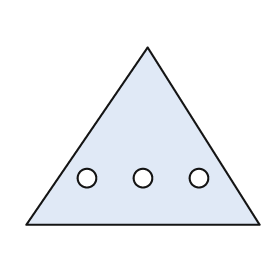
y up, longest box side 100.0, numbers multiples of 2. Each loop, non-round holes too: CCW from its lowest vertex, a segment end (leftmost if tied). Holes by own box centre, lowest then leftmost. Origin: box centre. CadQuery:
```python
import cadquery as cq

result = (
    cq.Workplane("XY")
    .moveTo(-50.0, -38.0)
    .lineTo(50.0, -38.0)
    .lineTo(2.0, 38.0)
    .close()
    .moveTo(-24.0, -18.0)
    .circle(4.0)
    .moveTo(0.0, -18.0)
    .circle(4.0)
    .moveTo(24.0, -18.0)
    .circle(4.0)
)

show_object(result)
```